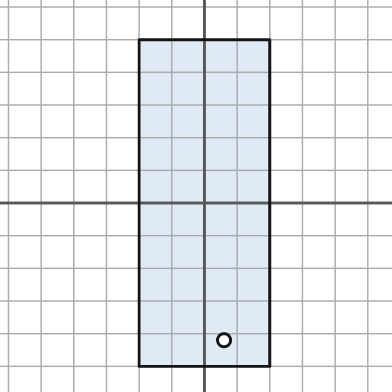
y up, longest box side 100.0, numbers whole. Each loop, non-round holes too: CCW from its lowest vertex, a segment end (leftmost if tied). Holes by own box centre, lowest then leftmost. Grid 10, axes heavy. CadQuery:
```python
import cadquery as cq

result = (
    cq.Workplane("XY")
    .moveTo(-20.0, -50.0)
    .lineTo(20.0, -50.0)
    .lineTo(20.0, 50.0)
    .lineTo(-20.0, 50.0)
    .close()
    .moveTo(6.0, -42.0)
    .circle(2.0)
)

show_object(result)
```